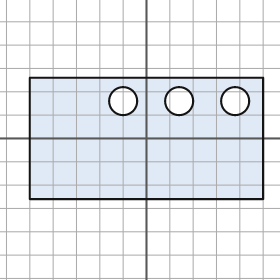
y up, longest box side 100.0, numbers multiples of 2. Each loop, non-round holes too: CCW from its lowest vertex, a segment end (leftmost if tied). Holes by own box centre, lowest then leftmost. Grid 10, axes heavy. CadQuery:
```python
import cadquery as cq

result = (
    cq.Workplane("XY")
    .moveTo(-50.0, -26.0)
    .lineTo(50.0, -26.0)
    .lineTo(50.0, 26.0)
    .lineTo(-50.0, 26.0)
    .close()
    .moveTo(-10.0, 16.0)
    .circle(6.0)
    .moveTo(14.0, 16.0)
    .circle(6.0)
    .moveTo(38.0, 16.0)
    .circle(6.0)
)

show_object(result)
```